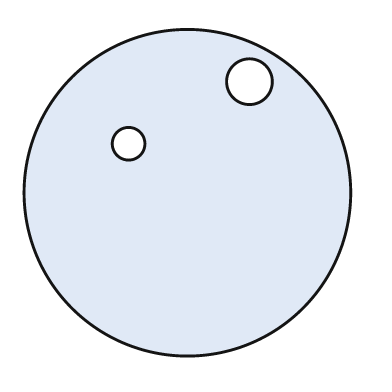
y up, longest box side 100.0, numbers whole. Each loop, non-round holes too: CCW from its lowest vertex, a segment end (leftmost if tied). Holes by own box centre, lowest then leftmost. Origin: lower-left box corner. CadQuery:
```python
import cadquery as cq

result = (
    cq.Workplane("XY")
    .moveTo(50.0, 50.0)
    .circle(50.0)
    .moveTo(32.0, 65.0)
    .circle(5.0)
    .moveTo(69.0, 84.0)
    .circle(7.0)
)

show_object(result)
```